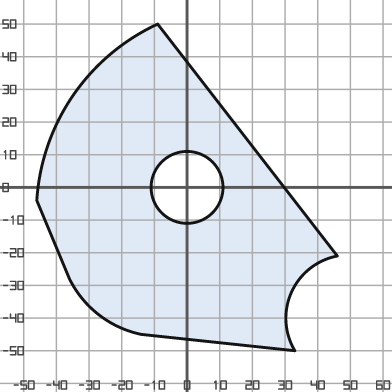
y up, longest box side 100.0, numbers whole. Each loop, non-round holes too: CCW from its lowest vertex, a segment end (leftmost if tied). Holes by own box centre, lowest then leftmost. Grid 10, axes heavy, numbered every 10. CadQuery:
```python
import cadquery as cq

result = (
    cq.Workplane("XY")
    .moveTo(33.0, -50.0)
    .threePointArc((32.0, -32.0), (46.0, -21.0))
    .lineTo(-9.0, 50.0)
    .threePointArc((-35.0, 28.0), (-46.0, -4.0))
    .lineTo(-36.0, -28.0)
    .threePointArc((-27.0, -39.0), (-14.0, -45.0))
    .close()
    .moveTo(0.0, 0.0)
    .circle(11.0)
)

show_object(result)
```